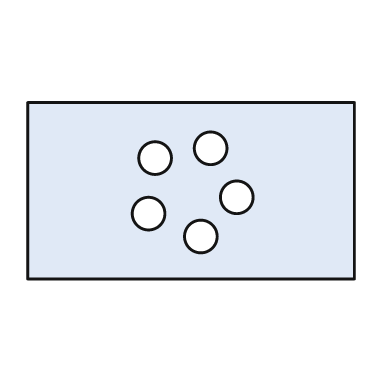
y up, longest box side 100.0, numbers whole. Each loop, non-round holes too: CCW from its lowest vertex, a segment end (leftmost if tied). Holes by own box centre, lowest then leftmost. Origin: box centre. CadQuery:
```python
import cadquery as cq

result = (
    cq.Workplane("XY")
    .moveTo(-50.0, -27.0)
    .lineTo(50.0, -27.0)
    .lineTo(50.0, 27.0)
    .lineTo(-50.0, 27.0)
    .close()
    .moveTo(3.0, -14.0)
    .circle(5.0)
    .moveTo(-13.0, -7.0)
    .circle(5.0)
    .moveTo(14.0, -2.0)
    .circle(5.0)
    .moveTo(-11.0, 10.0)
    .circle(5.0)
    .moveTo(6.0, 13.0)
    .circle(5.0)
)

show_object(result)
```